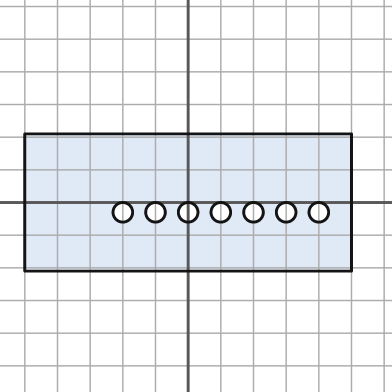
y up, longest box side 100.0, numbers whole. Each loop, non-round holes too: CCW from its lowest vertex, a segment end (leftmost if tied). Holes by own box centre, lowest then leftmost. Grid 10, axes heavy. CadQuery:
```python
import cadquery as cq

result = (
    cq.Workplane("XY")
    .moveTo(-50.0, -21.0)
    .lineTo(50.0, -21.0)
    .lineTo(50.0, 21.0)
    .lineTo(-50.0, 21.0)
    .close()
    .moveTo(-20.0, -3.0)
    .circle(3.0)
    .moveTo(-10.0, -3.0)
    .circle(3.0)
    .moveTo(0.0, -3.0)
    .circle(3.0)
    .moveTo(10.0, -3.0)
    .circle(3.0)
    .moveTo(20.0, -3.0)
    .circle(3.0)
    .moveTo(30.0, -3.0)
    .circle(3.0)
    .moveTo(40.0, -3.0)
    .circle(3.0)
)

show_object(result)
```